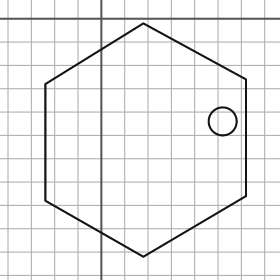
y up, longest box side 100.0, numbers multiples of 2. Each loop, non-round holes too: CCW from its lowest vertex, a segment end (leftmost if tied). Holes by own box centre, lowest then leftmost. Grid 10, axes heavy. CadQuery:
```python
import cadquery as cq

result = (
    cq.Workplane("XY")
    .moveTo(18.0, -102.0)
    .lineTo(62.0, -76.0)
    .lineTo(62.0, -26.0)
    .lineTo(18.0, -2.0)
    .lineTo(-24.0, -28.0)
    .lineTo(-24.0, -78.0)
    .close()
    .moveTo(52.0, -44.0)
    .circle(6.0)
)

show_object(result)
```